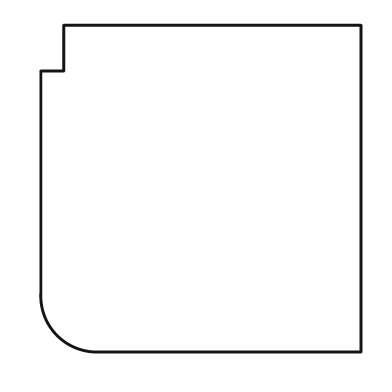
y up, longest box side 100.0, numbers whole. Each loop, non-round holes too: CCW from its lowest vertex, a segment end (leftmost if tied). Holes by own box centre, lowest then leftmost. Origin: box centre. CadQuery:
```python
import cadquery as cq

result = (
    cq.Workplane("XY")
    .moveTo(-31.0, -50.0)
    .lineTo(49.0, -50.0)
    .lineTo(49.0, 50.0)
    .lineTo(-42.0, 50.0)
    .lineTo(-42.0, 36.0)
    .lineTo(-49.0, 36.0)
    .lineTo(-49.0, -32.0)
    .threePointArc((-44.0, -45.0), (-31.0, -50.0))
    .close()
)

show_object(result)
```